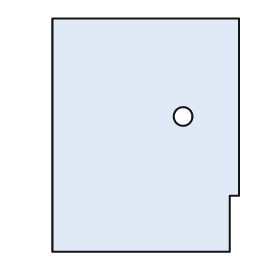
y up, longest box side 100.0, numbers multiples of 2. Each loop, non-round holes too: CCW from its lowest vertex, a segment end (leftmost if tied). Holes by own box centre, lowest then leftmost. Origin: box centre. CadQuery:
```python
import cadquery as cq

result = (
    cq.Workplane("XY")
    .moveTo(-40.0, -50.0)
    .lineTo(36.0, -50.0)
    .lineTo(36.0, -26.0)
    .lineTo(40.0, -26.0)
    .lineTo(40.0, 50.0)
    .lineTo(-40.0, 50.0)
    .close()
    .moveTo(16.0, 8.0)
    .circle(4.0)
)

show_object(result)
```